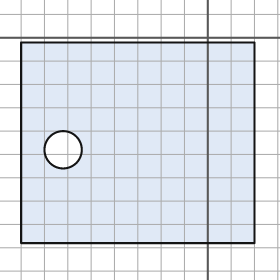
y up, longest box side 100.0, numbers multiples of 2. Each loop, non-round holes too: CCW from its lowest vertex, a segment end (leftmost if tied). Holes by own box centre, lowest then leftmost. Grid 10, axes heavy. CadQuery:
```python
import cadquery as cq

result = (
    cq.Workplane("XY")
    .moveTo(-80.0, -88.0)
    .lineTo(20.0, -88.0)
    .lineTo(20.0, -2.0)
    .lineTo(-80.0, -2.0)
    .close()
    .moveTo(-62.0, -48.0)
    .circle(8.0)
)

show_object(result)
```